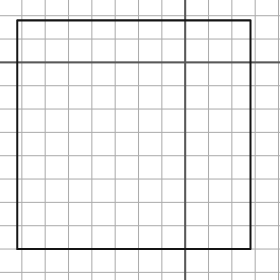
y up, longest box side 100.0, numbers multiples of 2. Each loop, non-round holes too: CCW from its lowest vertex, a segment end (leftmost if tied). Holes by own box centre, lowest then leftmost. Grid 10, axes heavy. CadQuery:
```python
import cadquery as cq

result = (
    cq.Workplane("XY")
    .moveTo(-72.0, -80.0)
    .lineTo(28.0, -80.0)
    .lineTo(28.0, 18.0)
    .lineTo(-72.0, 18.0)
    .close()
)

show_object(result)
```